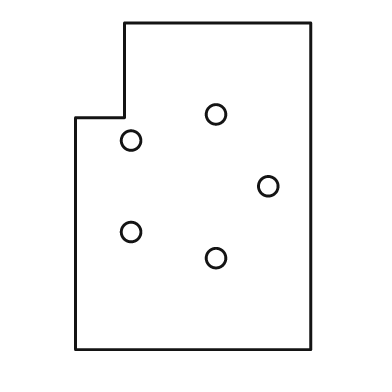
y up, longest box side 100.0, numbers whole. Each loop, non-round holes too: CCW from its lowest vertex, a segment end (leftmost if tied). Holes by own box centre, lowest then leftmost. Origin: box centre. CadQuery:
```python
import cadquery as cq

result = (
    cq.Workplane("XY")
    .moveTo(-36.0, -50.0)
    .lineTo(36.0, -50.0)
    .lineTo(36.0, 50.0)
    .lineTo(-21.0, 50.0)
    .lineTo(-21.0, 21.0)
    .lineTo(-36.0, 21.0)
    .close()
    .moveTo(7.0, -22.0)
    .circle(3.0)
    .moveTo(-19.0, -14.0)
    .circle(3.0)
    .moveTo(23.0, 0.0)
    .circle(3.0)
    .moveTo(-19.0, 14.0)
    .circle(3.0)
    .moveTo(7.0, 22.0)
    .circle(3.0)
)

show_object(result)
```